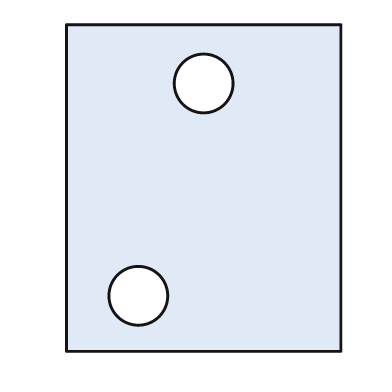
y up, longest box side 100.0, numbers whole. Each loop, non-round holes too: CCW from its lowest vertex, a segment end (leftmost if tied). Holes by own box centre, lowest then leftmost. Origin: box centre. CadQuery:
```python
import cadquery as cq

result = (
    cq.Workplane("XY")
    .moveTo(-42.0, -50.0)
    .lineTo(42.0, -50.0)
    .lineTo(42.0, 50.0)
    .lineTo(-42.0, 50.0)
    .close()
    .moveTo(-20.0, -33.0)
    .circle(9.0)
    .moveTo(0.0, 32.0)
    .circle(9.0)
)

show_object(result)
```